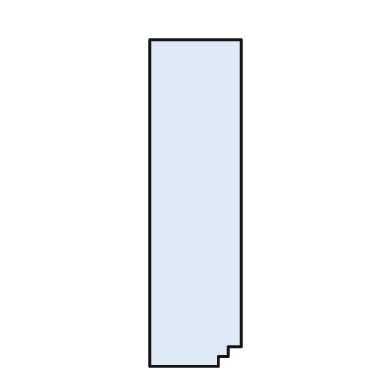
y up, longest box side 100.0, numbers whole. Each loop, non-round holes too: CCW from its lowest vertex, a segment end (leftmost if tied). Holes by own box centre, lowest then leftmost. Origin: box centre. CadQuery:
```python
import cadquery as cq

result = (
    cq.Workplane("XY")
    .moveTo(-14.0, -50.0)
    .lineTo(7.0, -50.0)
    .lineTo(7.0, -47.0)
    .lineTo(10.0, -47.0)
    .lineTo(10.0, -44.0)
    .lineTo(14.0, -44.0)
    .lineTo(14.0, 50.0)
    .lineTo(-14.0, 50.0)
    .close()
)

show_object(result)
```